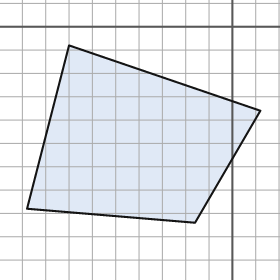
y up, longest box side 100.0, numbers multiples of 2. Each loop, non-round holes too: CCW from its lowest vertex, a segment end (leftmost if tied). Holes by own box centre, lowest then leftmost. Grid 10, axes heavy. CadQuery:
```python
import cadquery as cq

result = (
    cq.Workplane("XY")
    .moveTo(-16.0, -84.0)
    .lineTo(12.0, -36.0)
    .lineTo(-70.0, -8.0)
    .lineTo(-88.0, -78.0)
    .close()
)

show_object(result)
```